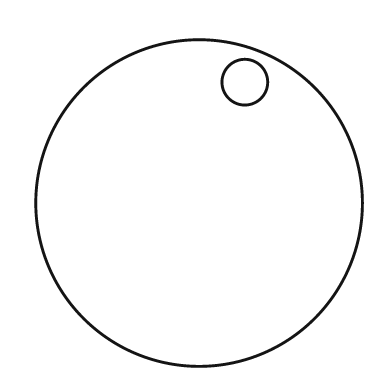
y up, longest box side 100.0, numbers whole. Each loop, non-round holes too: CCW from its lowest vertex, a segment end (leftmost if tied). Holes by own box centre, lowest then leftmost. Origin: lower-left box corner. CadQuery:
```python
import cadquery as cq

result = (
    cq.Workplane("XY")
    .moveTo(50.0, 50.0)
    .circle(50.0)
    .moveTo(64.0, 87.0)
    .circle(7.0)
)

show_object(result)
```